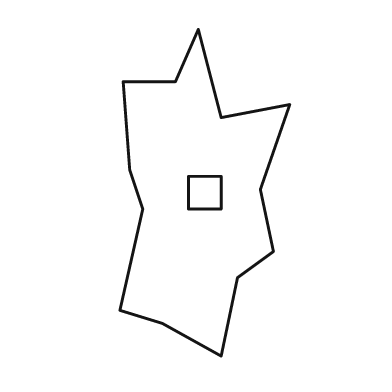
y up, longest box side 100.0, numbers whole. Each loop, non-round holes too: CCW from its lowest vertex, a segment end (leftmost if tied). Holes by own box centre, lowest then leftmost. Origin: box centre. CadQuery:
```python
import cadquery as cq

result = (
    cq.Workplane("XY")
    .moveTo(5.0, -50.0)
    .lineTo(10.0, -26.0)
    .lineTo(21.0, -18.0)
    .lineTo(17.0, 1.0)
    .lineTo(26.0, 27.0)
    .lineTo(5.0, 23.0)
    .lineTo(-2.0, 50.0)
    .lineTo(-9.0, 34.0)
    .lineTo(-25.0, 34.0)
    .lineTo(-23.0, 7.0)
    .lineTo(-19.0, -5.0)
    .lineTo(-26.0, -36.0)
    .lineTo(-13.0, -40.0)
    .close()
    .moveTo(-5.0, -5.0)
    .lineTo(5.0, -5.0)
    .lineTo(5.0, 5.0)
    .lineTo(-5.0, 5.0)
    .close()
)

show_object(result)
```